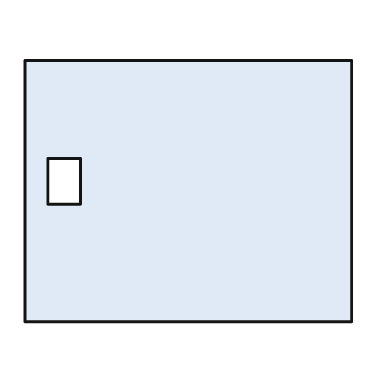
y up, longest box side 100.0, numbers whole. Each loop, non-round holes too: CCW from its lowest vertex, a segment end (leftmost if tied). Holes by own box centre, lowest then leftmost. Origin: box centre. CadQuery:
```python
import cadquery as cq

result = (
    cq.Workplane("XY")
    .moveTo(-50.0, -40.0)
    .lineTo(50.0, -40.0)
    .lineTo(50.0, 40.0)
    .lineTo(-50.0, 40.0)
    .close()
    .moveTo(-43.0, -4.0)
    .lineTo(-33.0, -4.0)
    .lineTo(-33.0, 10.0)
    .lineTo(-43.0, 10.0)
    .close()
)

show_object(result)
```